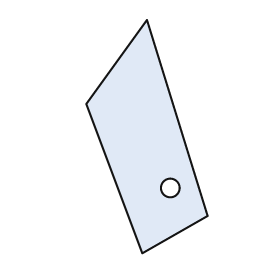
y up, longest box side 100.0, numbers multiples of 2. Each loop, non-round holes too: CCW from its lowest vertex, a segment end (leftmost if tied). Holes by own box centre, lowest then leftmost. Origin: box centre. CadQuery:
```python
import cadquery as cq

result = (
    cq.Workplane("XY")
    .moveTo(-2.0, -50.0)
    .lineTo(26.0, -34.0)
    .lineTo(0.0, 50.0)
    .lineTo(-26.0, 14.0)
    .close()
    .moveTo(10.0, -22.0)
    .circle(4.0)
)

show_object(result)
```